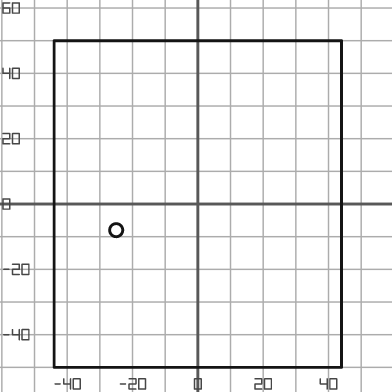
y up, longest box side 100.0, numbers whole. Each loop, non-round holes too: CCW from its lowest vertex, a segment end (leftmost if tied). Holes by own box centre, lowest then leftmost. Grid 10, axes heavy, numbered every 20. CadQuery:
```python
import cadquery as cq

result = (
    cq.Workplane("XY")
    .moveTo(-44.0, -50.0)
    .lineTo(44.0, -50.0)
    .lineTo(44.0, 50.0)
    .lineTo(-44.0, 50.0)
    .close()
    .moveTo(-25.0, -8.0)
    .circle(2.0)
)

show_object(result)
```